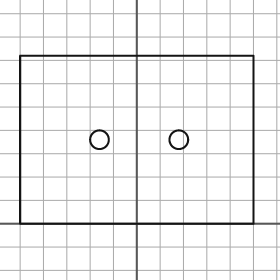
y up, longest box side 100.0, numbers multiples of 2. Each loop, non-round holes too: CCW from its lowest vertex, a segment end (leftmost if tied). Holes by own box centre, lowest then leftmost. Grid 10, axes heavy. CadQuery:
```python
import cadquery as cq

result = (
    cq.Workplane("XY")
    .moveTo(-50.0, 0.0)
    .lineTo(50.0, 0.0)
    .lineTo(50.0, 72.0)
    .lineTo(-50.0, 72.0)
    .close()
    .moveTo(-16.0, 36.0)
    .circle(4.0)
    .moveTo(18.0, 36.0)
    .circle(4.0)
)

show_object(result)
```